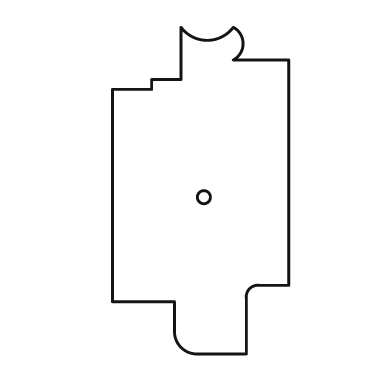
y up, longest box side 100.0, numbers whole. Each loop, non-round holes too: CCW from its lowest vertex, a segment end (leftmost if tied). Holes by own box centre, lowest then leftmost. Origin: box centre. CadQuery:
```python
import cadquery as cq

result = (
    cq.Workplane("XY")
    .moveTo(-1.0, -50.0)
    .lineTo(14.0, -50.0)
    .lineTo(14.0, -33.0)
    .threePointArc((15.0, -30.0), (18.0, -29.0))
    .lineTo(27.0, -29.0)
    .lineTo(27.0, 40.0)
    .lineTo(10.0, 40.0)
    .threePointArc((13.0, 45.0), (10.0, 50.0))
    .threePointArc((2.0, 46.0), (-6.0, 50.0))
    .lineTo(-6.0, 34.0)
    .lineTo(-15.0, 34.0)
    .lineTo(-15.0, 31.0)
    .lineTo(-27.0, 31.0)
    .lineTo(-27.0, -34.0)
    .lineTo(-8.0, -34.0)
    .lineTo(-8.0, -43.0)
    .threePointArc((-6.0, -48.0), (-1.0, -50.0))
    .close()
    .moveTo(1.0, -2.0)
    .circle(2.0)
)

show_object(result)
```